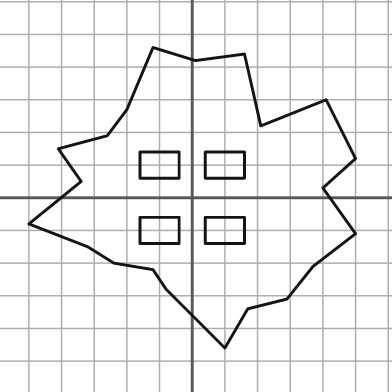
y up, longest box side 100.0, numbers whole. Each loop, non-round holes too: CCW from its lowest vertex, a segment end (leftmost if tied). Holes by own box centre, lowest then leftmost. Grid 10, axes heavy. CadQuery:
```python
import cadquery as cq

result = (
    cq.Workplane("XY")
    .moveTo(10.0, -46.0)
    .lineTo(17.0, -34.0)
    .lineTo(29.0, -31.0)
    .lineTo(37.0, -21.0)
    .lineTo(50.0, -11.0)
    .lineTo(40.0, 3.0)
    .lineTo(50.0, 12.0)
    .lineTo(41.0, 30.0)
    .lineTo(21.0, 22.0)
    .lineTo(16.0, 44.0)
    .lineTo(1.0, 42.0)
    .lineTo(-12.0, 46.0)
    .lineTo(-20.0, 27.0)
    .lineTo(-26.0, 19.0)
    .lineTo(-41.0, 15.0)
    .lineTo(-34.0, 5.0)
    .lineTo(-50.0, -8.0)
    .lineTo(-32.0, -15.0)
    .lineTo(-24.0, -20.0)
    .lineTo(-12.0, -22.0)
    .lineTo(-8.0, -28.0)
    .close()
    .moveTo(-16.0, -14.0)
    .lineTo(-4.0, -14.0)
    .lineTo(-4.0, -6.0)
    .lineTo(-16.0, -6.0)
    .close()
    .moveTo(4.0, -14.0)
    .lineTo(16.0, -14.0)
    .lineTo(16.0, -6.0)
    .lineTo(4.0, -6.0)
    .close()
    .moveTo(-16.0, 6.0)
    .lineTo(-4.0, 6.0)
    .lineTo(-4.0, 14.0)
    .lineTo(-16.0, 14.0)
    .close()
    .moveTo(4.0, 6.0)
    .lineTo(16.0, 6.0)
    .lineTo(16.0, 14.0)
    .lineTo(4.0, 14.0)
    .close()
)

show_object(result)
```